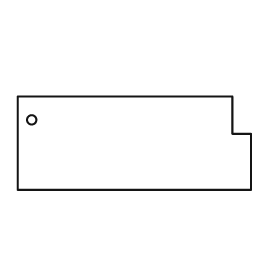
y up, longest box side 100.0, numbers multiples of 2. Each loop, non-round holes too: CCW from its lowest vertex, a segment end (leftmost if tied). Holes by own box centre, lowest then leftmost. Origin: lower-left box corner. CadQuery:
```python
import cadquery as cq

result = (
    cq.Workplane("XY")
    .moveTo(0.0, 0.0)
    .lineTo(100.0, 0.0)
    .lineTo(100.0, 24.0)
    .lineTo(92.0, 24.0)
    .lineTo(92.0, 40.0)
    .lineTo(0.0, 40.0)
    .close()
    .moveTo(6.0, 30.0)
    .circle(2.0)
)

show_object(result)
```